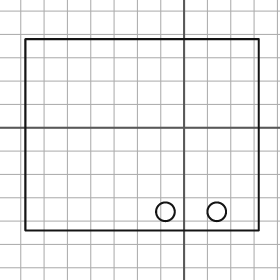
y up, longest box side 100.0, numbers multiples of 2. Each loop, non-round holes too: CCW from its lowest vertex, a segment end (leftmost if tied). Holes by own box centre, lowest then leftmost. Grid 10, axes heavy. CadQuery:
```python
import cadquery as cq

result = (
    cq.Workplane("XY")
    .moveTo(-68.0, -44.0)
    .lineTo(32.0, -44.0)
    .lineTo(32.0, 38.0)
    .lineTo(-68.0, 38.0)
    .close()
    .moveTo(-8.0, -36.0)
    .circle(4.0)
    .moveTo(14.0, -36.0)
    .circle(4.0)
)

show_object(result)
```